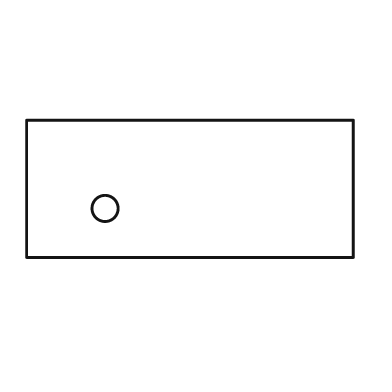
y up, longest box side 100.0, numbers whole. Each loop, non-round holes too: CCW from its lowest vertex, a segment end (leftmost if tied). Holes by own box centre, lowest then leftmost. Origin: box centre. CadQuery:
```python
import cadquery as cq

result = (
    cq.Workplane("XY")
    .moveTo(-50.0, -21.0)
    .lineTo(50.0, -21.0)
    .lineTo(50.0, 21.0)
    .lineTo(-50.0, 21.0)
    .close()
    .moveTo(-26.0, -6.0)
    .circle(4.0)
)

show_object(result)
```